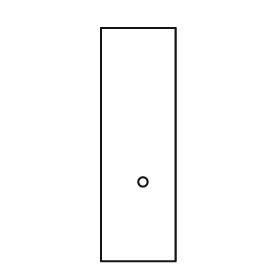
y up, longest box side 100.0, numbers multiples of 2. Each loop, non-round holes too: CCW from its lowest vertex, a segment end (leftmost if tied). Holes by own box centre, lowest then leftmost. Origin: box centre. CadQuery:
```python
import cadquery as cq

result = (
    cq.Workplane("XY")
    .moveTo(-16.0, -50.0)
    .lineTo(16.0, -50.0)
    .lineTo(16.0, 50.0)
    .lineTo(-16.0, 50.0)
    .close()
    .moveTo(2.0, -16.0)
    .circle(2.0)
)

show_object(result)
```